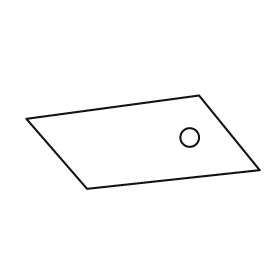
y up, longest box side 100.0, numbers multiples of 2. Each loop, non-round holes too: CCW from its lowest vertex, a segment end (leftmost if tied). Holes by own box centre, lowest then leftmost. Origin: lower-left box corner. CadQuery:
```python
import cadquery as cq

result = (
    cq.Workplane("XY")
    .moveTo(26.0, 0.0)
    .lineTo(100.0, 8.0)
    .lineTo(74.0, 40.0)
    .lineTo(0.0, 30.0)
    .close()
    .moveTo(70.0, 22.0)
    .circle(4.0)
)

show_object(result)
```